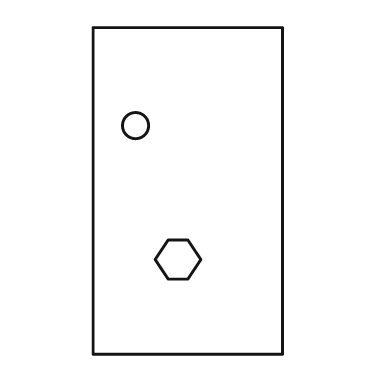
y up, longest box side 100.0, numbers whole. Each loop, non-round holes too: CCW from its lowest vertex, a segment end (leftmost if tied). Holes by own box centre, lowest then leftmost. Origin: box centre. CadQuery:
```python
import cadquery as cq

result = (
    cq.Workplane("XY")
    .moveTo(-29.0, -50.0)
    .lineTo(29.0, -50.0)
    .lineTo(29.0, 50.0)
    .lineTo(-29.0, 50.0)
    .close()
    .moveTo(-6.0, -27.0)
    .lineTo(0.0, -27.0)
    .lineTo(4.0, -21.0)
    .lineTo(0.0, -15.0)
    .lineTo(-6.0, -15.0)
    .lineTo(-10.0, -21.0)
    .close()
    .moveTo(-16.0, 20.0)
    .circle(4.0)
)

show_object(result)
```